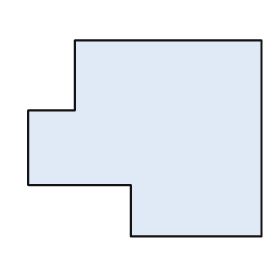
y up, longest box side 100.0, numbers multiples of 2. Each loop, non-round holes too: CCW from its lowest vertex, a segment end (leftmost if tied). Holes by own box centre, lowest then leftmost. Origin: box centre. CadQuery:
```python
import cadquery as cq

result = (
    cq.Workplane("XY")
    .moveTo(-6.0, -42.0)
    .lineTo(50.0, -42.0)
    .lineTo(50.0, 42.0)
    .lineTo(-30.0, 42.0)
    .lineTo(-30.0, 12.0)
    .lineTo(-50.0, 12.0)
    .lineTo(-50.0, -20.0)
    .lineTo(-6.0, -20.0)
    .close()
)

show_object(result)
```